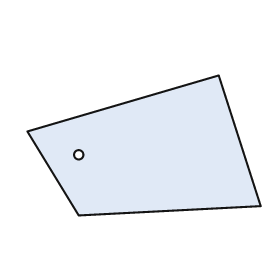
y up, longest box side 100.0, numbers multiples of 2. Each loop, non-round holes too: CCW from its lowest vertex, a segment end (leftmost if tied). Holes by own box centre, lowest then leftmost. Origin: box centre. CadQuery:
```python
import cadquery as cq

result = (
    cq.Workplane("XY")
    .moveTo(-28.0, -30.0)
    .lineTo(50.0, -26.0)
    .lineTo(32.0, 30.0)
    .lineTo(-50.0, 6.0)
    .close()
    .moveTo(-28.0, -4.0)
    .circle(2.0)
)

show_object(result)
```